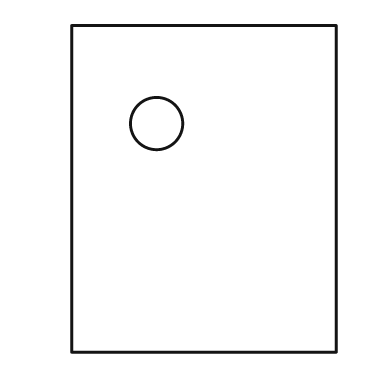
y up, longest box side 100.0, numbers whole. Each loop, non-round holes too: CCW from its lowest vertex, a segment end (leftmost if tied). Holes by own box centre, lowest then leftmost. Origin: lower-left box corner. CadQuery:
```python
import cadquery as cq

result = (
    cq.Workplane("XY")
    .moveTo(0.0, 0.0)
    .lineTo(81.0, 0.0)
    .lineTo(81.0, 100.0)
    .lineTo(0.0, 100.0)
    .close()
    .moveTo(26.0, 70.0)
    .circle(8.0)
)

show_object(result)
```